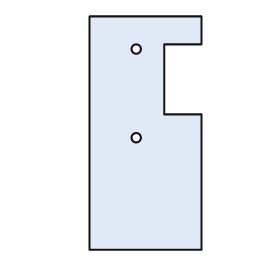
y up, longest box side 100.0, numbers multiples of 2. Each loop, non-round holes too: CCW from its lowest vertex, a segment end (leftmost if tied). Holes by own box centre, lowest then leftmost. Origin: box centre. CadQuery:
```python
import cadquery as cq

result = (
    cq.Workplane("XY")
    .moveTo(-24.0, -50.0)
    .lineTo(24.0, -50.0)
    .lineTo(24.0, 8.0)
    .lineTo(8.0, 8.0)
    .lineTo(8.0, 38.0)
    .lineTo(24.0, 38.0)
    .lineTo(24.0, 50.0)
    .lineTo(-24.0, 50.0)
    .close()
    .moveTo(-4.0, -2.0)
    .circle(2.0)
    .moveTo(-4.0, 36.0)
    .circle(2.0)
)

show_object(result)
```